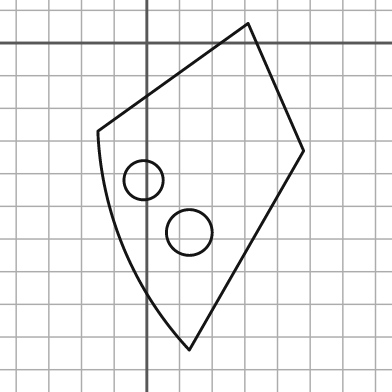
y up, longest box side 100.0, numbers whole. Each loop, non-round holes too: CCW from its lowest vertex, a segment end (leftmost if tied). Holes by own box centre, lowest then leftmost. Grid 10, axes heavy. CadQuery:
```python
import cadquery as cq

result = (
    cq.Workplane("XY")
    .moveTo(13.0, -94.0)
    .lineTo(48.0, -33.0)
    .lineTo(31.0, 6.0)
    .lineTo(-15.0, -27.0)
    .threePointArc((-7.0, -63.0), (13.0, -94.0))
    .close()
    .moveTo(13.0, -58.0)
    .circle(7.0)
    .moveTo(-1.0, -42.0)
    .circle(6.0)
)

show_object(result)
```